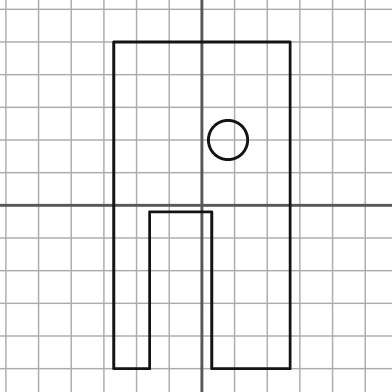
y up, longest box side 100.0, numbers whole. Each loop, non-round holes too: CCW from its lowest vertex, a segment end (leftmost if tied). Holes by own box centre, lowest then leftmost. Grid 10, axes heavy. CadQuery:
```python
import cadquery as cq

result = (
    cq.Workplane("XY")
    .moveTo(-27.0, -50.0)
    .lineTo(-16.0, -50.0)
    .lineTo(-16.0, -2.0)
    .lineTo(3.0, -2.0)
    .lineTo(3.0, -50.0)
    .lineTo(27.0, -50.0)
    .lineTo(27.0, 50.0)
    .lineTo(-27.0, 50.0)
    .close()
    .moveTo(8.0, 20.0)
    .circle(6.0)
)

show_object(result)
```